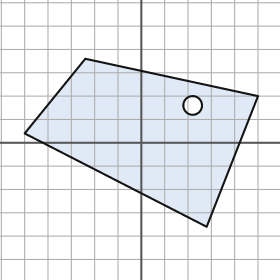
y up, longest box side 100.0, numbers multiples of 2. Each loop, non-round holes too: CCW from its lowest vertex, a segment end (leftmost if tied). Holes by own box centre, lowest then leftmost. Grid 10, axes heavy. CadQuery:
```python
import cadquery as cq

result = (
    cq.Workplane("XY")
    .moveTo(28.0, -36.0)
    .lineTo(50.0, 20.0)
    .lineTo(-24.0, 36.0)
    .lineTo(-50.0, 4.0)
    .close()
    .moveTo(22.0, 16.0)
    .circle(4.0)
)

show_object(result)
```